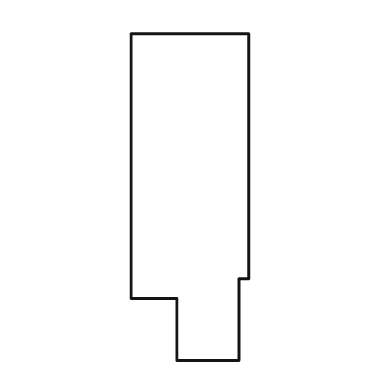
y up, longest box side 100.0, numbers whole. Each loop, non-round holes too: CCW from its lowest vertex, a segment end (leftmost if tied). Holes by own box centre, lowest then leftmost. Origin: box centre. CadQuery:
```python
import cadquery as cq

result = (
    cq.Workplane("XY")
    .moveTo(-4.0, -50.0)
    .lineTo(15.0, -50.0)
    .lineTo(15.0, -25.0)
    .lineTo(18.0, -25.0)
    .lineTo(18.0, 50.0)
    .lineTo(-18.0, 50.0)
    .lineTo(-18.0, -31.0)
    .lineTo(-4.0, -31.0)
    .close()
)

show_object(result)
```